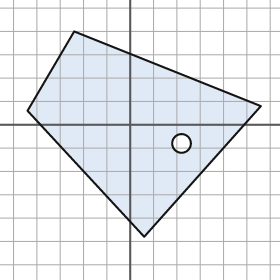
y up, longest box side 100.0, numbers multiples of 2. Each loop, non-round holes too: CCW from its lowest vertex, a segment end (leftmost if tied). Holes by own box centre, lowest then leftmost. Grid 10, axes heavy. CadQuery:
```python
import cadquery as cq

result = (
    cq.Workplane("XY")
    .moveTo(6.0, -48.0)
    .lineTo(56.0, 8.0)
    .lineTo(-24.0, 40.0)
    .lineTo(-44.0, 6.0)
    .close()
    .moveTo(22.0, -8.0)
    .circle(4.0)
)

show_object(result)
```